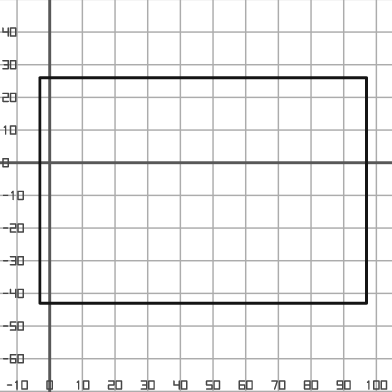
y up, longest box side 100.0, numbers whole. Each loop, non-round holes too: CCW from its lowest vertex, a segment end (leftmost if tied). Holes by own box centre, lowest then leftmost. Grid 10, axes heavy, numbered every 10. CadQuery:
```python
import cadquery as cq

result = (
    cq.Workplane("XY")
    .moveTo(-3.0, -43.0)
    .lineTo(97.0, -43.0)
    .lineTo(97.0, 26.0)
    .lineTo(-3.0, 26.0)
    .close()
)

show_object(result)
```